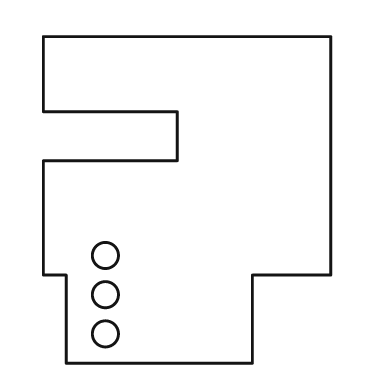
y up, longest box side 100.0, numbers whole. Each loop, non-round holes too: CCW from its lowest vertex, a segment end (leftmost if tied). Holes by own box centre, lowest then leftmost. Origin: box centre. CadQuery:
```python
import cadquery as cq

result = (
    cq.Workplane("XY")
    .moveTo(-37.0, -50.0)
    .lineTo(20.0, -50.0)
    .lineTo(20.0, -23.0)
    .lineTo(44.0, -23.0)
    .lineTo(44.0, 50.0)
    .lineTo(-44.0, 50.0)
    .lineTo(-44.0, 27.0)
    .lineTo(-3.0, 27.0)
    .lineTo(-3.0, 12.0)
    .lineTo(-44.0, 12.0)
    .lineTo(-44.0, -23.0)
    .lineTo(-37.0, -23.0)
    .close()
    .moveTo(-25.0, -41.0)
    .circle(4.0)
    .moveTo(-25.0, -29.0)
    .circle(4.0)
    .moveTo(-25.0, -17.0)
    .circle(4.0)
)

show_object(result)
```